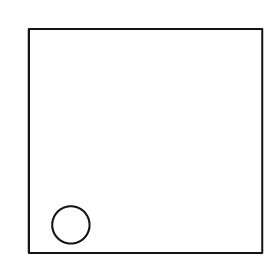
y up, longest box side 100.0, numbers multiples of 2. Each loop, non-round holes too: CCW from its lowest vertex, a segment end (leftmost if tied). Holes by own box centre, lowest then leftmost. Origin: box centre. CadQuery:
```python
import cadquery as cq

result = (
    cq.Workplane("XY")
    .moveTo(-50.0, -48.0)
    .lineTo(50.0, -48.0)
    .lineTo(50.0, 48.0)
    .lineTo(-50.0, 48.0)
    .close()
    .moveTo(-32.0, -36.0)
    .circle(8.0)
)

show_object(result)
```